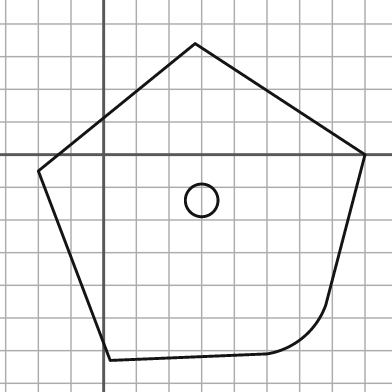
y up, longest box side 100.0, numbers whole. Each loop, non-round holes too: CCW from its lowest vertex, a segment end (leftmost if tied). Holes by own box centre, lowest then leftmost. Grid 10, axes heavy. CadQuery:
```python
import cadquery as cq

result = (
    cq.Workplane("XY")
    .moveTo(2.0, -63.0)
    .lineTo(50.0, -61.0)
    .threePointArc((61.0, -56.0), (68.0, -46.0))
    .lineTo(80.0, 0.0)
    .lineTo(28.0, 34.0)
    .lineTo(-20.0, -5.0)
    .close()
    .moveTo(30.0, -14.0)
    .circle(5.0)
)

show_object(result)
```